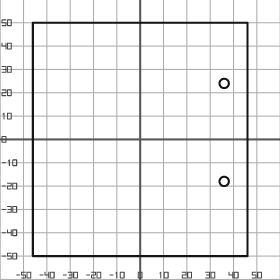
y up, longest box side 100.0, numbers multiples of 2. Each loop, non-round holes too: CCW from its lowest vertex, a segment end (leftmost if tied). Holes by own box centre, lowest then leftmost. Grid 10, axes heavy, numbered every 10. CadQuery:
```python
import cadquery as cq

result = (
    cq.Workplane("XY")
    .moveTo(-46.0, -50.0)
    .lineTo(46.0, -50.0)
    .lineTo(46.0, 50.0)
    .lineTo(-46.0, 50.0)
    .close()
    .moveTo(36.0, -18.0)
    .circle(2.0)
    .moveTo(36.0, 24.0)
    .circle(2.0)
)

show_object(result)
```